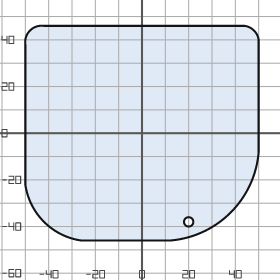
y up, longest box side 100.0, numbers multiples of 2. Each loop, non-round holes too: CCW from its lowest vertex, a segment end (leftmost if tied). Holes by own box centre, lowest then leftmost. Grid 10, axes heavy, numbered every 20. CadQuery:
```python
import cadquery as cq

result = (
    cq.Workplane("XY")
    .moveTo(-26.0, -46.0)
    .lineTo(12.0, -46.0)
    .threePointArc((38.0, -34.0), (50.0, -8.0))
    .lineTo(50.0, 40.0)
    .threePointArc((48.0, 44.0), (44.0, 46.0))
    .lineTo(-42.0, 46.0)
    .threePointArc((-48.0, 44.0), (-50.0, 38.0))
    .lineTo(-50.0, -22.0)
    .threePointArc((-42.0, -38.0), (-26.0, -46.0))
    .close()
    .moveTo(20.0, -38.0)
    .circle(2.0)
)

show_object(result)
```